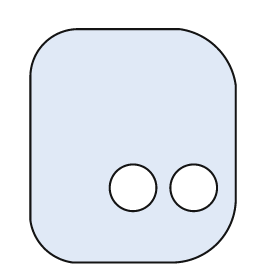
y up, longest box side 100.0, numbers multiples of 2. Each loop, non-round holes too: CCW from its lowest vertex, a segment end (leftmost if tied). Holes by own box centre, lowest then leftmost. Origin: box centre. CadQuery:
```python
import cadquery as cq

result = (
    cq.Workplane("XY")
    .moveTo(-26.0, -50.0)
    .lineTo(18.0, -50.0)
    .threePointArc((36.0, -42.0), (44.0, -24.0))
    .lineTo(44.0, 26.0)
    .threePointArc((36.0, 42.0), (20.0, 50.0))
    .lineTo(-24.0, 50.0)
    .threePointArc((-38.0, 44.0), (-44.0, 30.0))
    .lineTo(-44.0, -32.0)
    .threePointArc((-38.0, -44.0), (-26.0, -50.0))
    .close()
    .moveTo(0.0, -18.0)
    .circle(10.0)
    .moveTo(26.0, -18.0)
    .circle(10.0)
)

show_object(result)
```